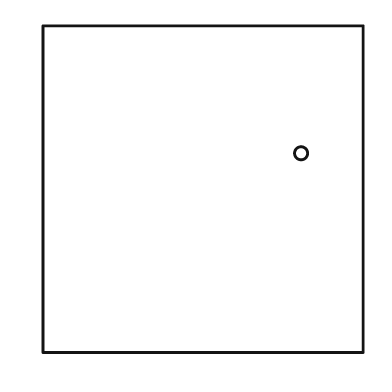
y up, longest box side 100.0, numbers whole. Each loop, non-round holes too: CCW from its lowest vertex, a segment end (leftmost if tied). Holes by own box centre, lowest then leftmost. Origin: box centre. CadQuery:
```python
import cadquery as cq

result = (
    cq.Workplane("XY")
    .moveTo(-49.0, -50.0)
    .lineTo(49.0, -50.0)
    .lineTo(49.0, 50.0)
    .lineTo(-49.0, 50.0)
    .close()
    .moveTo(30.0, 11.0)
    .circle(2.0)
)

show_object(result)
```